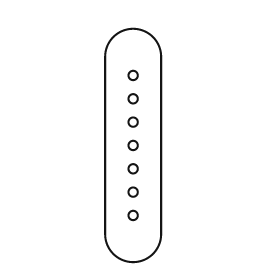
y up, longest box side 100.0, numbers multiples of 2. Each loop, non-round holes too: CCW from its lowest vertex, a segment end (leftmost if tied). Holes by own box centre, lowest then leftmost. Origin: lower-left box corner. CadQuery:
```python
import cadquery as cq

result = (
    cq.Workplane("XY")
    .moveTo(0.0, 12.0)
    .threePointArc((12.0, 0.0), (24.0, 12.0))
    .lineTo(24.0, 88.0)
    .threePointArc((12.0, 100.0), (0.0, 88.0))
    .close()
    .moveTo(12.0, 20.0)
    .circle(2.0)
    .moveTo(12.0, 30.0)
    .circle(2.0)
    .moveTo(12.0, 40.0)
    .circle(2.0)
    .moveTo(12.0, 50.0)
    .circle(2.0)
    .moveTo(12.0, 60.0)
    .circle(2.0)
    .moveTo(12.0, 70.0)
    .circle(2.0)
    .moveTo(12.0, 80.0)
    .circle(2.0)
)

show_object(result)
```